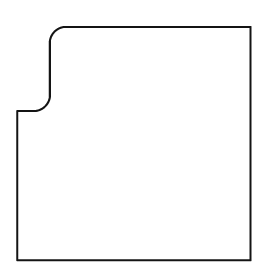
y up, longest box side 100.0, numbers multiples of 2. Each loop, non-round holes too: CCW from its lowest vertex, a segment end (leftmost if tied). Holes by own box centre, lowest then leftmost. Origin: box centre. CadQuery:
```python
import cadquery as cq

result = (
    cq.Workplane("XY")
    .moveTo(-50.0, -50.0)
    .lineTo(50.0, -50.0)
    .lineTo(50.0, 50.0)
    .lineTo(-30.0, 50.0)
    .threePointArc((-34.0, 48.0), (-36.0, 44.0))
    .lineTo(-36.0, 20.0)
    .threePointArc((-38.0, 16.0), (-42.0, 14.0))
    .lineTo(-50.0, 14.0)
    .close()
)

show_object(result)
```